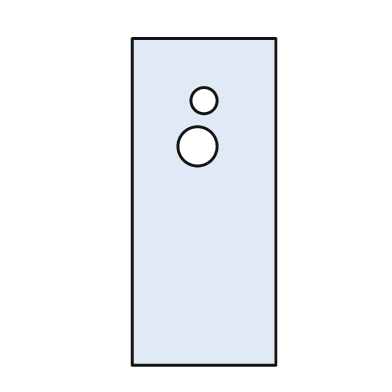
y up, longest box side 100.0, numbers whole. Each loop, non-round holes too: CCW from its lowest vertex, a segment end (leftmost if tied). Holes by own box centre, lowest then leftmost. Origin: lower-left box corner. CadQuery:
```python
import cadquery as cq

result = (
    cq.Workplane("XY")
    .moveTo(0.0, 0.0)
    .lineTo(44.0, 0.0)
    .lineTo(44.0, 100.0)
    .lineTo(0.0, 100.0)
    .close()
    .moveTo(20.0, 67.0)
    .circle(6.0)
    .moveTo(22.0, 81.0)
    .circle(4.0)
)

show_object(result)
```